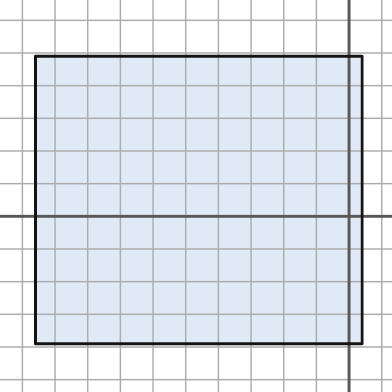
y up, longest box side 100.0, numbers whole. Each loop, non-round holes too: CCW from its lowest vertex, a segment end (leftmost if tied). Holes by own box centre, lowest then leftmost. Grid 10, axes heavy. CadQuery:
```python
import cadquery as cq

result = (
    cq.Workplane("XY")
    .moveTo(-96.0, -39.0)
    .lineTo(4.0, -39.0)
    .lineTo(4.0, 49.0)
    .lineTo(-96.0, 49.0)
    .close()
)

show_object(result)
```